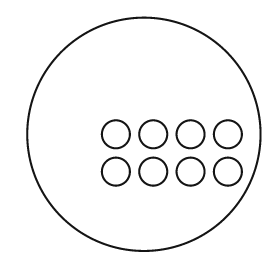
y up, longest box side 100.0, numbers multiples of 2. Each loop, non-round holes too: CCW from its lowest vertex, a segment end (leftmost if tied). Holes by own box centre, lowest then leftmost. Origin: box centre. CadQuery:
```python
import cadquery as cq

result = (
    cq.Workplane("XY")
    .moveTo(0.0, 0.0)
    .circle(50.0)
    .moveTo(-12.0, -16.0)
    .circle(6.0)
    .moveTo(4.0, -16.0)
    .circle(6.0)
    .moveTo(20.0, -16.0)
    .circle(6.0)
    .moveTo(36.0, -16.0)
    .circle(6.0)
    .moveTo(-12.0, 0.0)
    .circle(6.0)
    .moveTo(4.0, 0.0)
    .circle(6.0)
    .moveTo(20.0, 0.0)
    .circle(6.0)
    .moveTo(36.0, 0.0)
    .circle(6.0)
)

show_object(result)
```